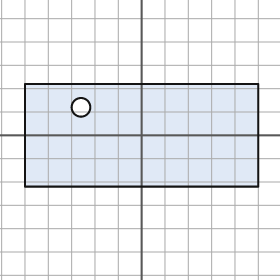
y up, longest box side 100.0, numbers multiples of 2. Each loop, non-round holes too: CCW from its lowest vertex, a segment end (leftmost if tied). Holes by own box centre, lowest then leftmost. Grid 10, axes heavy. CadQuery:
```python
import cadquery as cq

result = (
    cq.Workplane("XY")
    .moveTo(-50.0, -22.0)
    .lineTo(50.0, -22.0)
    .lineTo(50.0, 22.0)
    .lineTo(-50.0, 22.0)
    .close()
    .moveTo(-26.0, 12.0)
    .circle(4.0)
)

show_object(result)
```